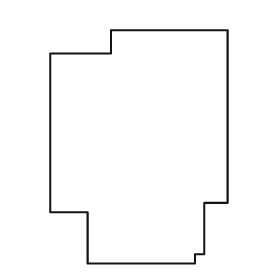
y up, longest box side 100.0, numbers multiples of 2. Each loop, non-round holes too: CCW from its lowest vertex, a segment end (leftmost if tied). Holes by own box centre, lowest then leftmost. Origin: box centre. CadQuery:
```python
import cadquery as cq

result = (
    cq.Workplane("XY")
    .moveTo(-22.0, -50.0)
    .lineTo(24.0, -50.0)
    .lineTo(24.0, -46.0)
    .lineTo(28.0, -46.0)
    .lineTo(28.0, -24.0)
    .lineTo(38.0, -24.0)
    .lineTo(38.0, 50.0)
    .lineTo(-12.0, 50.0)
    .lineTo(-12.0, 40.0)
    .lineTo(-38.0, 40.0)
    .lineTo(-38.0, -28.0)
    .lineTo(-22.0, -28.0)
    .close()
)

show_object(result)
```